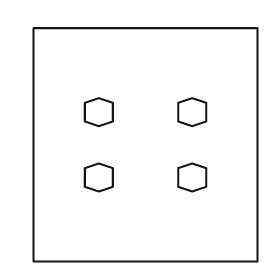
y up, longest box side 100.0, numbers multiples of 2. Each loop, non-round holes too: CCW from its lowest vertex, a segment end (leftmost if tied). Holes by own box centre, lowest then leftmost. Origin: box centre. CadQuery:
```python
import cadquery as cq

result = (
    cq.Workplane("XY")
    .moveTo(-48.0, -50.0)
    .lineTo(48.0, -50.0)
    .lineTo(48.0, 50.0)
    .lineTo(-48.0, 50.0)
    .close()
    .moveTo(-20.0, -20.0)
    .lineTo(-14.0, -18.0)
    .lineTo(-14.0, -10.0)
    .lineTo(-20.0, -8.0)
    .lineTo(-26.0, -10.0)
    .lineTo(-26.0, -18.0)
    .close()
    .moveTo(20.0, -20.0)
    .lineTo(26.0, -18.0)
    .lineTo(26.0, -10.0)
    .lineTo(20.0, -8.0)
    .lineTo(14.0, -10.0)
    .lineTo(14.0, -18.0)
    .close()
    .moveTo(-20.0, 8.0)
    .lineTo(-14.0, 10.0)
    .lineTo(-14.0, 18.0)
    .lineTo(-20.0, 20.0)
    .lineTo(-26.0, 18.0)
    .lineTo(-26.0, 10.0)
    .close()
    .moveTo(20.0, 8.0)
    .lineTo(26.0, 10.0)
    .lineTo(26.0, 18.0)
    .lineTo(20.0, 20.0)
    .lineTo(14.0, 18.0)
    .lineTo(14.0, 10.0)
    .close()
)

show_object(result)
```